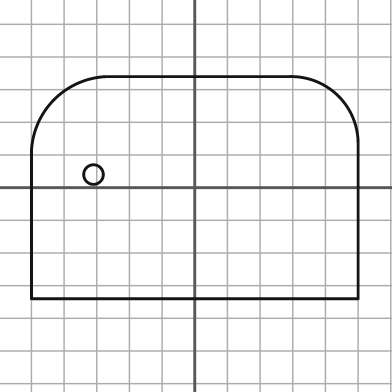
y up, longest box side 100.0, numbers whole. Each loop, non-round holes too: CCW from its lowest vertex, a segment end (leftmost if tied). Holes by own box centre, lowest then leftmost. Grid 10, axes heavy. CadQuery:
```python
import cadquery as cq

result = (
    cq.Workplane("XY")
    .moveTo(-50.0, -34.0)
    .lineTo(50.0, -34.0)
    .lineTo(50.0, 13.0)
    .threePointArc((44.0, 28.0), (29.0, 34.0))
    .lineTo(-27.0, 34.0)
    .threePointArc((-43.0, 27.0), (-50.0, 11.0))
    .close()
    .moveTo(-31.0, 4.0)
    .circle(3.0)
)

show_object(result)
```